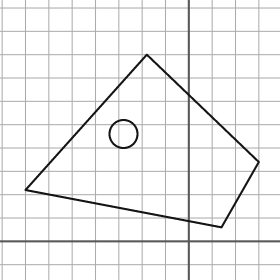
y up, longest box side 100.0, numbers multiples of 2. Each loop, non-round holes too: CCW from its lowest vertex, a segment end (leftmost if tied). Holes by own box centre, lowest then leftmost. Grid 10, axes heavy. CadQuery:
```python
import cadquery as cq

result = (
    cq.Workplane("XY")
    .moveTo(14.0, 6.0)
    .lineTo(30.0, 34.0)
    .lineTo(-18.0, 80.0)
    .lineTo(-70.0, 22.0)
    .close()
    .moveTo(-28.0, 46.0)
    .circle(6.0)
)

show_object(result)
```